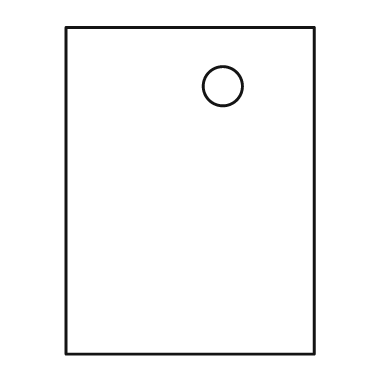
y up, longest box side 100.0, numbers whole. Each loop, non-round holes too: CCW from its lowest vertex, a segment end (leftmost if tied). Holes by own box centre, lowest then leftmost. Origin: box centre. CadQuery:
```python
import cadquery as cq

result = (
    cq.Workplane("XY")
    .moveTo(-38.0, -50.0)
    .lineTo(38.0, -50.0)
    .lineTo(38.0, 50.0)
    .lineTo(-38.0, 50.0)
    .close()
    .moveTo(10.0, 32.0)
    .circle(6.0)
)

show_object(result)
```